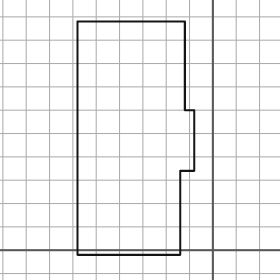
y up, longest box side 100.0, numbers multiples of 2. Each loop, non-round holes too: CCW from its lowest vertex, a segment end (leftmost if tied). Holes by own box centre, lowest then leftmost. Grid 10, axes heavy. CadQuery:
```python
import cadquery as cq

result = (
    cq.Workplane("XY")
    .moveTo(-58.0, -2.0)
    .lineTo(-14.0, -2.0)
    .lineTo(-14.0, 34.0)
    .lineTo(-8.0, 34.0)
    .lineTo(-8.0, 60.0)
    .lineTo(-12.0, 60.0)
    .lineTo(-12.0, 98.0)
    .lineTo(-58.0, 98.0)
    .close()
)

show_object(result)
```